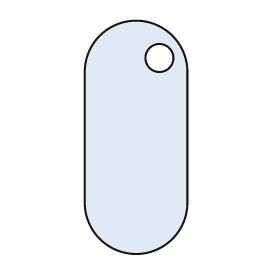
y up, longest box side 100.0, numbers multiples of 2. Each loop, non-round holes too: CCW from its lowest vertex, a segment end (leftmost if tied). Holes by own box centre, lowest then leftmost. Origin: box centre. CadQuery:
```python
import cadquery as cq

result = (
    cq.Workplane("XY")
    .moveTo(-22.0, -28.0)
    .threePointArc((0.0, -50.0), (22.0, -28.0))
    .lineTo(22.0, 28.0)
    .threePointArc((0.0, 50.0), (-22.0, 28.0))
    .close()
    .moveTo(10.0, 34.0)
    .circle(6.0)
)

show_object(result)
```